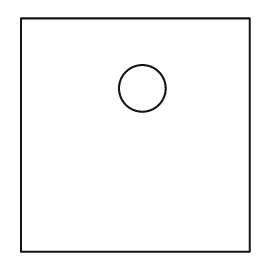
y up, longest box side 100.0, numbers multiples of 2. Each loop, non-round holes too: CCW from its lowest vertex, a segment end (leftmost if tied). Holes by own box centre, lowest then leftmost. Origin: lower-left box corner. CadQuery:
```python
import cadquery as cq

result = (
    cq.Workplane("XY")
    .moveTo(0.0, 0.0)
    .lineTo(98.0, 0.0)
    .lineTo(98.0, 100.0)
    .lineTo(0.0, 100.0)
    .close()
    .moveTo(52.0, 70.0)
    .circle(10.0)
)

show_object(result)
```